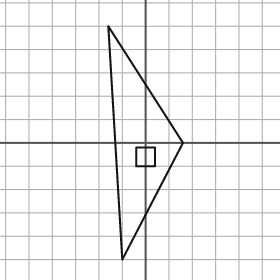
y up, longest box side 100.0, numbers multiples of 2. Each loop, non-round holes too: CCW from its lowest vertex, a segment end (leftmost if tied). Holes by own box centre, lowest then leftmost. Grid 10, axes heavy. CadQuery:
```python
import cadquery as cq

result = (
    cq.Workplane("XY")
    .moveTo(-10.0, -50.0)
    .lineTo(16.0, 0.0)
    .lineTo(-16.0, 50.0)
    .close()
    .moveTo(-4.0, -10.0)
    .lineTo(4.0, -10.0)
    .lineTo(4.0, -2.0)
    .lineTo(-4.0, -2.0)
    .close()
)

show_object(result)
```